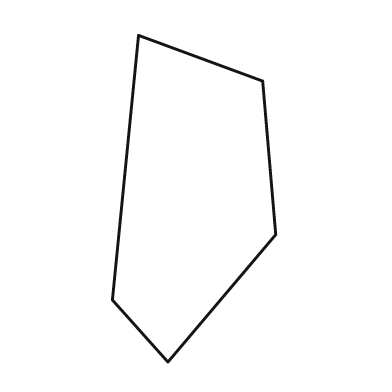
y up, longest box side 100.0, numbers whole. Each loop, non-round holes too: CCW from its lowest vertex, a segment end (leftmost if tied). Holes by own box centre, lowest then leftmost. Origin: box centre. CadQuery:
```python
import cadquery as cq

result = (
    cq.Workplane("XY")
    .moveTo(-8.0, -50.0)
    .lineTo(25.0, -11.0)
    .lineTo(21.0, 36.0)
    .lineTo(-17.0, 50.0)
    .lineTo(-25.0, -31.0)
    .close()
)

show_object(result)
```